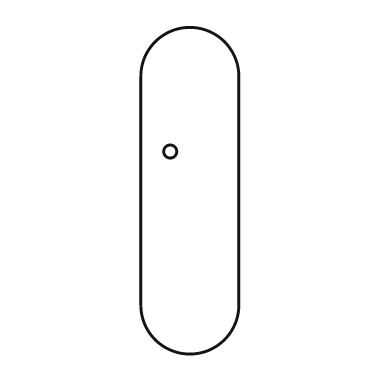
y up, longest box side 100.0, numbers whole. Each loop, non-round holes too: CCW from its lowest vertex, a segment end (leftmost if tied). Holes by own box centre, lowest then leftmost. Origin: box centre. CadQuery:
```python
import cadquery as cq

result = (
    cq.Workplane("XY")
    .moveTo(-15.0, -35.0)
    .threePointArc((0.0, -50.0), (15.0, -35.0))
    .lineTo(15.0, 35.0)
    .threePointArc((0.0, 50.0), (-15.0, 35.0))
    .close()
    .moveTo(-6.0, 12.0)
    .circle(2.0)
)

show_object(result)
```